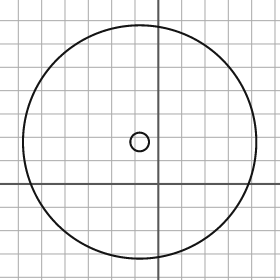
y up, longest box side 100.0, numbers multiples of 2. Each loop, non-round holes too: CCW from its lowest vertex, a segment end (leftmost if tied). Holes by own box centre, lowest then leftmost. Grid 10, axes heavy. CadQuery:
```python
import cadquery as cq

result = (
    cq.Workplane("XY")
    .moveTo(-8.0, 18.0)
    .circle(50.0)
    .moveTo(-8.0, 18.0)
    .circle(4.0)
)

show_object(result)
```